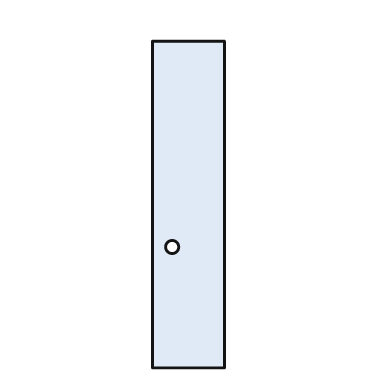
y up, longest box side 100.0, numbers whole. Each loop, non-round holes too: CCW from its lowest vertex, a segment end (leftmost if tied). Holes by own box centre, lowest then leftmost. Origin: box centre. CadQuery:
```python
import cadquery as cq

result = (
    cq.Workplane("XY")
    .moveTo(-11.0, -50.0)
    .lineTo(11.0, -50.0)
    .lineTo(11.0, 50.0)
    .lineTo(-11.0, 50.0)
    .close()
    .moveTo(-5.0, -13.0)
    .circle(2.0)
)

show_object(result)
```